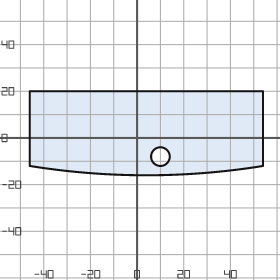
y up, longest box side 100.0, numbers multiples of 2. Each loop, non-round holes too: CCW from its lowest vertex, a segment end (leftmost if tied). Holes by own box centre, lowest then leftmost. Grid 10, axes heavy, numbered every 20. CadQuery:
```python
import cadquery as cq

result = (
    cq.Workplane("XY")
    .moveTo(-46.0, -12.0)
    .threePointArc((4.0, -16.0), (54.0, -12.0))
    .lineTo(54.0, 20.0)
    .lineTo(-46.0, 20.0)
    .close()
    .moveTo(10.0, -8.0)
    .circle(4.0)
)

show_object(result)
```